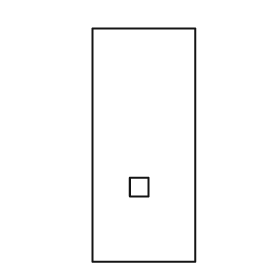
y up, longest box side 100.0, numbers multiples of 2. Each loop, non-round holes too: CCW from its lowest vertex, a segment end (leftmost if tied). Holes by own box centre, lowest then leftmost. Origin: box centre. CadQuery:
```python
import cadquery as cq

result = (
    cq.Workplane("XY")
    .moveTo(-22.0, -50.0)
    .lineTo(22.0, -50.0)
    .lineTo(22.0, 50.0)
    .lineTo(-22.0, 50.0)
    .close()
    .moveTo(-6.0, -22.0)
    .lineTo(2.0, -22.0)
    .lineTo(2.0, -14.0)
    .lineTo(-6.0, -14.0)
    .close()
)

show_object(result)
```